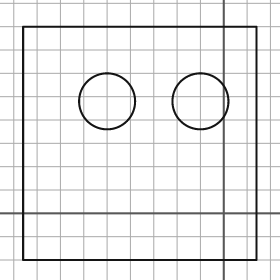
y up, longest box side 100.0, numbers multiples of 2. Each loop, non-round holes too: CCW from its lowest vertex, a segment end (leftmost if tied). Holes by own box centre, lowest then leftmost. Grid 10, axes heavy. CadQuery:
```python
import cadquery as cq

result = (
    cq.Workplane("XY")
    .moveTo(-86.0, -20.0)
    .lineTo(14.0, -20.0)
    .lineTo(14.0, 80.0)
    .lineTo(-86.0, 80.0)
    .close()
    .moveTo(-50.0, 48.0)
    .circle(12.0)
    .moveTo(-10.0, 48.0)
    .circle(12.0)
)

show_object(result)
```